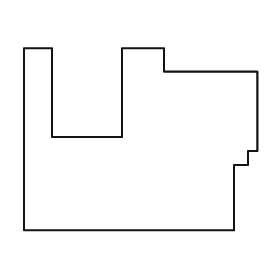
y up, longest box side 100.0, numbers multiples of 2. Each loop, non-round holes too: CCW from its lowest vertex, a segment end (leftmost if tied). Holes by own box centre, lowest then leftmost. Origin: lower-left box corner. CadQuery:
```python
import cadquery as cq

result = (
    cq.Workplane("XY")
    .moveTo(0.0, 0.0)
    .lineTo(90.0, 0.0)
    .lineTo(90.0, 28.0)
    .lineTo(96.0, 28.0)
    .lineTo(96.0, 34.0)
    .lineTo(100.0, 34.0)
    .lineTo(100.0, 68.0)
    .lineTo(60.0, 68.0)
    .lineTo(60.0, 78.0)
    .lineTo(42.0, 78.0)
    .lineTo(42.0, 40.0)
    .lineTo(12.0, 40.0)
    .lineTo(12.0, 78.0)
    .lineTo(0.0, 78.0)
    .close()
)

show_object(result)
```